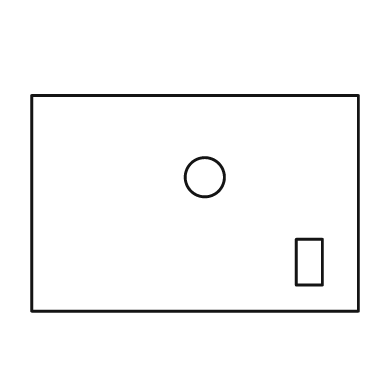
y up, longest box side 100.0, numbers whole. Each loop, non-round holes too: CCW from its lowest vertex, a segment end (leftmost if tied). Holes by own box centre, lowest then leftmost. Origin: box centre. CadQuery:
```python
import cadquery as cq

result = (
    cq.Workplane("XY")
    .moveTo(-50.0, -33.0)
    .lineTo(50.0, -33.0)
    .lineTo(50.0, 33.0)
    .lineTo(-50.0, 33.0)
    .close()
    .moveTo(31.0, -25.0)
    .lineTo(39.0, -25.0)
    .lineTo(39.0, -11.0)
    .lineTo(31.0, -11.0)
    .close()
    .moveTo(3.0, 8.0)
    .circle(6.0)
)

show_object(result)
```